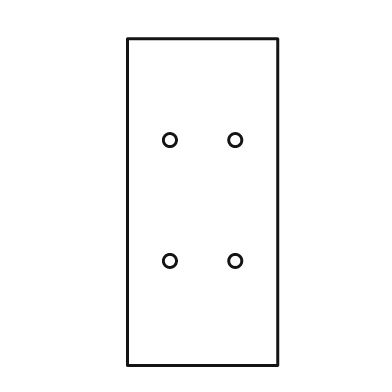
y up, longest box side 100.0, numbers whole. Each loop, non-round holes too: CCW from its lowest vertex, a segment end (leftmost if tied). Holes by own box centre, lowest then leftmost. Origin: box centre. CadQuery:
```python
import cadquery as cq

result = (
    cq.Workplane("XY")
    .moveTo(-23.0, -50.0)
    .lineTo(23.0, -50.0)
    .lineTo(23.0, 50.0)
    .lineTo(-23.0, 50.0)
    .close()
    .moveTo(-10.0, -18.0)
    .circle(2.0)
    .moveTo(10.0, -18.0)
    .circle(2.0)
    .moveTo(-10.0, 19.0)
    .circle(2.0)
    .moveTo(10.0, 19.0)
    .circle(2.0)
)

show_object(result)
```